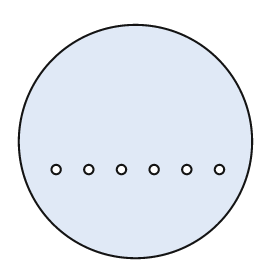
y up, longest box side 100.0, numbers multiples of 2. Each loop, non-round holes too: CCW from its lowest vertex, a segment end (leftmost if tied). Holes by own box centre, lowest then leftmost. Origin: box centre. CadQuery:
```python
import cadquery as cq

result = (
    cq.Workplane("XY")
    .moveTo(0.0, 0.0)
    .circle(50.0)
    .moveTo(-34.0, -12.0)
    .circle(2.0)
    .moveTo(-20.0, -12.0)
    .circle(2.0)
    .moveTo(-6.0, -12.0)
    .circle(2.0)
    .moveTo(8.0, -12.0)
    .circle(2.0)
    .moveTo(22.0, -12.0)
    .circle(2.0)
    .moveTo(36.0, -12.0)
    .circle(2.0)
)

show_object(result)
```